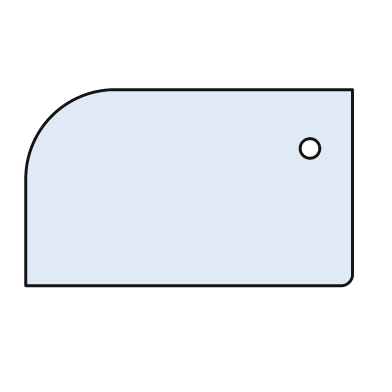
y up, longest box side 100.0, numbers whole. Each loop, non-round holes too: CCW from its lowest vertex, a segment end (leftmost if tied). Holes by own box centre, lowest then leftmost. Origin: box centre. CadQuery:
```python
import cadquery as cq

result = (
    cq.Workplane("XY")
    .moveTo(-50.0, -30.0)
    .lineTo(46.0, -30.0)
    .threePointArc((49.0, -29.0), (50.0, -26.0))
    .lineTo(50.0, 30.0)
    .lineTo(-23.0, 30.0)
    .threePointArc((-42.0, 22.0), (-50.0, 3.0))
    .close()
    .moveTo(37.0, 12.0)
    .circle(3.0)
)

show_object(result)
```